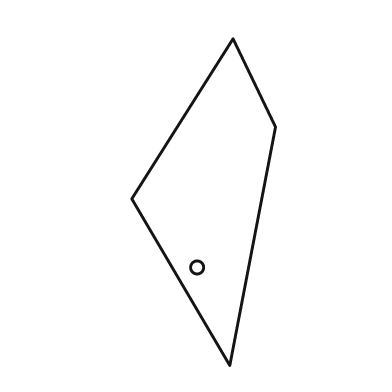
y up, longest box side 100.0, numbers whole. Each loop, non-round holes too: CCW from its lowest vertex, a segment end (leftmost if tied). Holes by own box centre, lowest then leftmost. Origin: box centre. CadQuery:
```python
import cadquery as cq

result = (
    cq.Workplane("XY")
    .moveTo(8.0, -50.0)
    .lineTo(22.0, 23.0)
    .lineTo(9.0, 50.0)
    .lineTo(-22.0, 1.0)
    .close()
    .moveTo(-2.0, -20.0)
    .circle(2.0)
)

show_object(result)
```